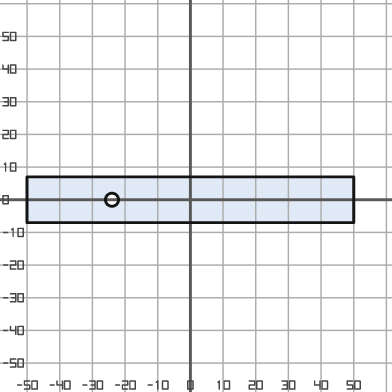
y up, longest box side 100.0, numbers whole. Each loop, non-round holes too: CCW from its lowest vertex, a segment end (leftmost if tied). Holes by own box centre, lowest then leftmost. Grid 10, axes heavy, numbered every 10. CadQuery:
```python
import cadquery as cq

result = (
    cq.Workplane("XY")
    .moveTo(-50.0, -7.0)
    .lineTo(50.0, -7.0)
    .lineTo(50.0, 7.0)
    .lineTo(-50.0, 7.0)
    .close()
    .moveTo(-24.0, 0.0)
    .circle(2.0)
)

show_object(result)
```